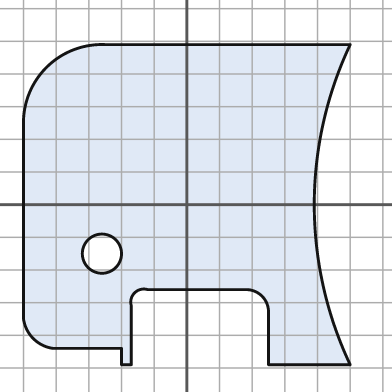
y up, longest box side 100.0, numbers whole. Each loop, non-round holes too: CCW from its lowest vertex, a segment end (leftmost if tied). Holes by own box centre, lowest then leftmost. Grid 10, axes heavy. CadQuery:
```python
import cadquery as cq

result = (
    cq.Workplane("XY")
    .moveTo(-20.0, -49.0)
    .lineTo(-17.0, -49.0)
    .lineTo(-17.0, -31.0)
    .threePointArc((-16.0, -27.0), (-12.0, -26.0))
    .lineTo(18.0, -26.0)
    .threePointArc((23.0, -28.0), (25.0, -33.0))
    .lineTo(25.0, -49.0)
    .lineTo(50.0, -49.0)
    .threePointArc((39.0, 0.0), (50.0, 49.0))
    .lineTo(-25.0, 49.0)
    .threePointArc((-43.0, 42.0), (-50.0, 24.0))
    .lineTo(-50.0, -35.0)
    .threePointArc((-47.0, -41.0), (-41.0, -44.0))
    .lineTo(-20.0, -44.0)
    .close()
    .moveTo(-26.0, -15.0)
    .circle(6.0)
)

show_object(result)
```